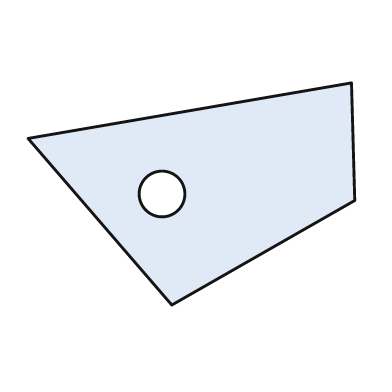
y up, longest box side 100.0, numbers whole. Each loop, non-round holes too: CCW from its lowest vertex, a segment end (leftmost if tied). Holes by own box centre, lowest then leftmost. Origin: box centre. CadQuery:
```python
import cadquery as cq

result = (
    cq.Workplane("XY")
    .moveTo(-6.0, -34.0)
    .lineTo(50.0, -2.0)
    .lineTo(49.0, 34.0)
    .lineTo(-50.0, 17.0)
    .close()
    .moveTo(-9.0, 0.0)
    .circle(7.0)
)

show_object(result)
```